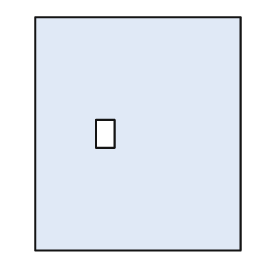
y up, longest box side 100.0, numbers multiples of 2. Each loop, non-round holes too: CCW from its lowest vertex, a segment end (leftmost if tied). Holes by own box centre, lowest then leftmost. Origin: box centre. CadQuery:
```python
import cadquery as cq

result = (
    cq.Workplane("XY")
    .moveTo(-44.0, -50.0)
    .lineTo(44.0, -50.0)
    .lineTo(44.0, 50.0)
    .lineTo(-44.0, 50.0)
    .close()
    .moveTo(-18.0, -6.0)
    .lineTo(-10.0, -6.0)
    .lineTo(-10.0, 6.0)
    .lineTo(-18.0, 6.0)
    .close()
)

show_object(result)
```